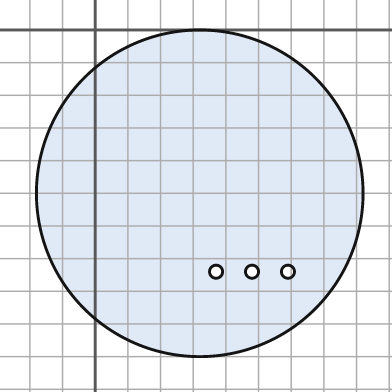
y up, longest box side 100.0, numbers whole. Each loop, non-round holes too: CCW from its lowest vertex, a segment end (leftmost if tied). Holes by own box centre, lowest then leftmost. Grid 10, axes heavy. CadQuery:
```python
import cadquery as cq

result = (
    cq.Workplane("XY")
    .moveTo(32.0, -50.0)
    .circle(50.0)
    .moveTo(37.0, -74.0)
    .circle(2.0)
    .moveTo(48.0, -74.0)
    .circle(2.0)
    .moveTo(59.0, -74.0)
    .circle(2.0)
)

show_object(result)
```